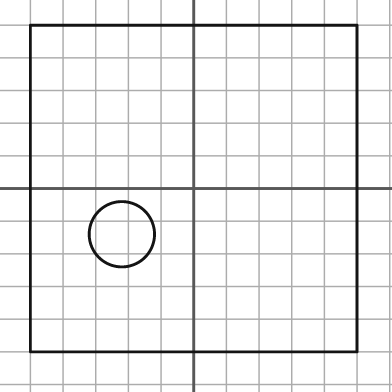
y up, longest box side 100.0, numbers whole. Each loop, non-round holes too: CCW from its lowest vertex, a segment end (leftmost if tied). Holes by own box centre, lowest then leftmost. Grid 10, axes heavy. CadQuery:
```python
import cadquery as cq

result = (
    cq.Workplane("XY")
    .moveTo(-50.0, -50.0)
    .lineTo(50.0, -50.0)
    .lineTo(50.0, 50.0)
    .lineTo(-50.0, 50.0)
    .close()
    .moveTo(-22.0, -14.0)
    .circle(10.0)
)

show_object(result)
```